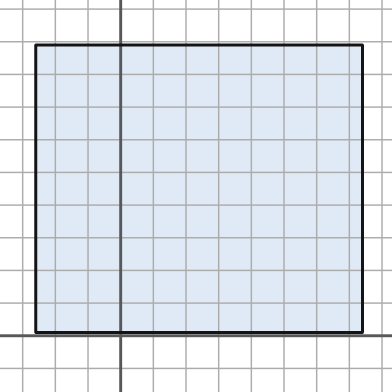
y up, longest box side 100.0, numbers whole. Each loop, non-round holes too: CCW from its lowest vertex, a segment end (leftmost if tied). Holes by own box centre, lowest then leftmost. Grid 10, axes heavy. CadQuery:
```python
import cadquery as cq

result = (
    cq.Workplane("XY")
    .moveTo(-26.0, 1.0)
    .lineTo(74.0, 1.0)
    .lineTo(74.0, 89.0)
    .lineTo(-26.0, 89.0)
    .close()
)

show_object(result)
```